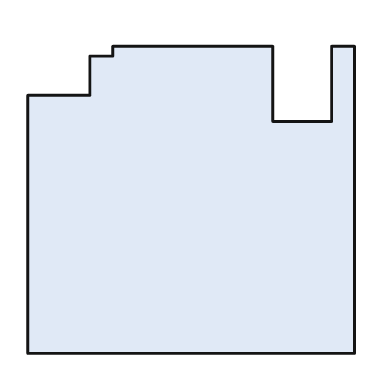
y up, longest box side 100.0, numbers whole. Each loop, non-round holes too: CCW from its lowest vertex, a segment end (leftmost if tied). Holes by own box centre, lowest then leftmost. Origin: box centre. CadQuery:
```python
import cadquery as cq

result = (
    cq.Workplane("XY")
    .moveTo(-50.0, -47.0)
    .lineTo(50.0, -47.0)
    .lineTo(50.0, 47.0)
    .lineTo(43.0, 47.0)
    .lineTo(43.0, 24.0)
    .lineTo(25.0, 24.0)
    .lineTo(25.0, 47.0)
    .lineTo(-24.0, 47.0)
    .lineTo(-24.0, 44.0)
    .lineTo(-31.0, 44.0)
    .lineTo(-31.0, 32.0)
    .lineTo(-50.0, 32.0)
    .close()
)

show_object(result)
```